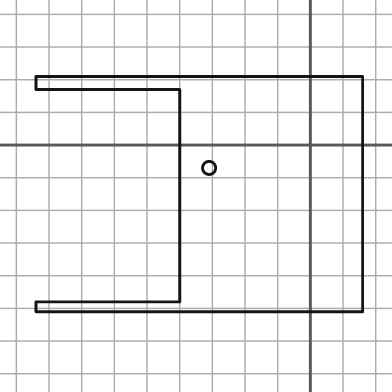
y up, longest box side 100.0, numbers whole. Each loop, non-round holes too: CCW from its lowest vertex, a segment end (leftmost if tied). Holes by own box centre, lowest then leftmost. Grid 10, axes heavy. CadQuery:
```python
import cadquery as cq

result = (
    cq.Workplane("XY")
    .moveTo(-84.0, -51.0)
    .lineTo(16.0, -51.0)
    .lineTo(16.0, 21.0)
    .lineTo(-84.0, 21.0)
    .lineTo(-84.0, 17.0)
    .lineTo(-40.0, 17.0)
    .lineTo(-40.0, -48.0)
    .lineTo(-84.0, -48.0)
    .close()
    .moveTo(-31.0, -7.0)
    .circle(2.0)
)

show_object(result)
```